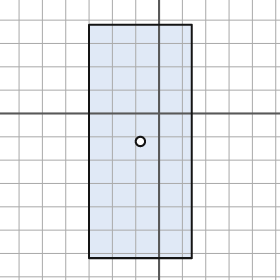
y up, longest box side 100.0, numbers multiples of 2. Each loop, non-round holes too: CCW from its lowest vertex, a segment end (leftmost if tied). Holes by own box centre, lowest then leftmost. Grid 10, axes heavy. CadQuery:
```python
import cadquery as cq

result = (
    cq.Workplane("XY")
    .moveTo(-30.0, -62.0)
    .lineTo(14.0, -62.0)
    .lineTo(14.0, 38.0)
    .lineTo(-30.0, 38.0)
    .close()
    .moveTo(-8.0, -12.0)
    .circle(2.0)
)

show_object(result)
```